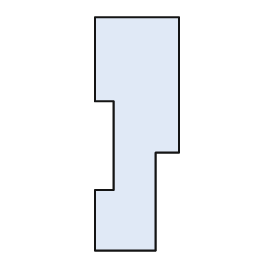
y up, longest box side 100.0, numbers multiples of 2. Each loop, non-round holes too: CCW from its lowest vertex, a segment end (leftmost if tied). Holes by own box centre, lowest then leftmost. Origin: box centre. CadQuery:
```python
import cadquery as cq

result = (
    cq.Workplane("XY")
    .moveTo(-18.0, -50.0)
    .lineTo(8.0, -50.0)
    .lineTo(8.0, -8.0)
    .lineTo(18.0, -8.0)
    .lineTo(18.0, 50.0)
    .lineTo(-18.0, 50.0)
    .lineTo(-18.0, 14.0)
    .lineTo(-10.0, 14.0)
    .lineTo(-10.0, -24.0)
    .lineTo(-18.0, -24.0)
    .close()
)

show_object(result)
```